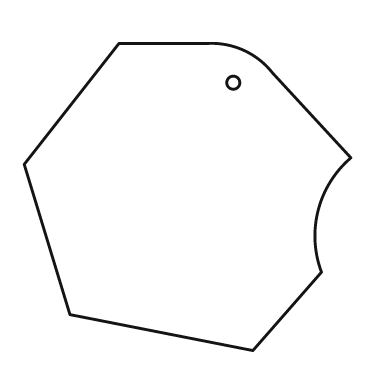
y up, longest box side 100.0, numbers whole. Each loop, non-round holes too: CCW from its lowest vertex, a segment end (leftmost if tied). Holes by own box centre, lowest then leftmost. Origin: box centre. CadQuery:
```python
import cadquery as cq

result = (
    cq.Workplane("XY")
    .moveTo(20.0, -47.0)
    .lineTo(41.0, -23.0)
    .threePointArc((40.0, -4.0), (50.0, 12.0))
    .lineTo(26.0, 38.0)
    .threePointArc((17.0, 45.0), (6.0, 47.0))
    .lineTo(-21.0, 47.0)
    .lineTo(-50.0, 10.0)
    .lineTo(-36.0, -36.0)
    .close()
    .moveTo(14.0, 35.0)
    .circle(2.0)
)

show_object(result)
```